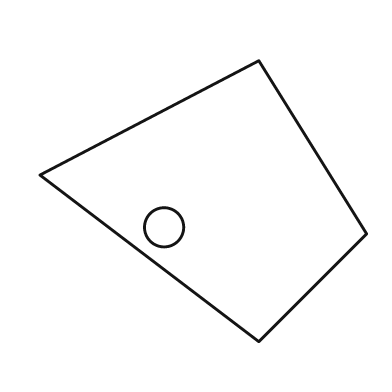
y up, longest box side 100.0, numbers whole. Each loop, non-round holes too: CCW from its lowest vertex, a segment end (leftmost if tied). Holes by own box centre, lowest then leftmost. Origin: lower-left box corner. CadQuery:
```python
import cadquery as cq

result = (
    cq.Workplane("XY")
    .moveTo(67.0, 0.0)
    .lineTo(100.0, 33.0)
    .lineTo(67.0, 86.0)
    .lineTo(0.0, 51.0)
    .close()
    .moveTo(38.0, 35.0)
    .circle(6.0)
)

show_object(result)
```